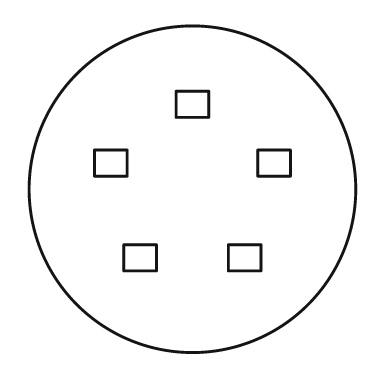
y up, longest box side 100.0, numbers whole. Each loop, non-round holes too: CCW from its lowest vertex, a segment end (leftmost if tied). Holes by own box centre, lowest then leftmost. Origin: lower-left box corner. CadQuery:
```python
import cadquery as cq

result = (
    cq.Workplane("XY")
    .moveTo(50.0, 50.0)
    .circle(50.0)
    .moveTo(29.0, 25.0)
    .lineTo(39.0, 25.0)
    .lineTo(39.0, 33.0)
    .lineTo(29.0, 33.0)
    .close()
    .moveTo(61.0, 25.0)
    .lineTo(71.0, 25.0)
    .lineTo(71.0, 33.0)
    .lineTo(61.0, 33.0)
    .close()
    .moveTo(20.0, 54.0)
    .lineTo(30.0, 54.0)
    .lineTo(30.0, 62.0)
    .lineTo(20.0, 62.0)
    .close()
    .moveTo(70.0, 54.0)
    .lineTo(80.0, 54.0)
    .lineTo(80.0, 62.0)
    .lineTo(70.0, 62.0)
    .close()
    .moveTo(45.0, 72.0)
    .lineTo(55.0, 72.0)
    .lineTo(55.0, 80.0)
    .lineTo(45.0, 80.0)
    .close()
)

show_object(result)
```